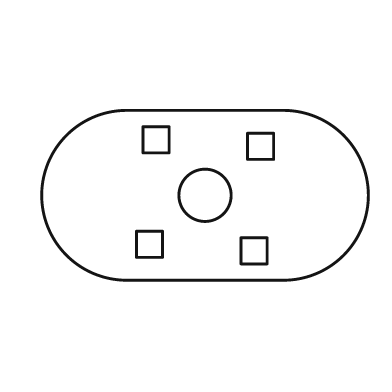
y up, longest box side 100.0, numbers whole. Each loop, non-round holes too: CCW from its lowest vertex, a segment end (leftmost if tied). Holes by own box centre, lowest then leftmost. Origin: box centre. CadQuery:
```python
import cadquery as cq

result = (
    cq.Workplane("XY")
    .moveTo(-24.0, -26.0)
    .lineTo(24.0, -26.0)
    .threePointArc((50.0, 0.0), (24.0, 26.0))
    .lineTo(-24.0, 26.0)
    .threePointArc((-50.0, 0.0), (-24.0, -26.0))
    .close()
    .moveTo(11.0, -21.0)
    .lineTo(19.0, -21.0)
    .lineTo(19.0, -13.0)
    .lineTo(11.0, -13.0)
    .close()
    .moveTo(-21.0, -19.0)
    .lineTo(-13.0, -19.0)
    .lineTo(-13.0, -11.0)
    .lineTo(-21.0, -11.0)
    .close()
    .moveTo(0.0, 0.0)
    .circle(8.0)
    .moveTo(13.0, 11.0)
    .lineTo(21.0, 11.0)
    .lineTo(21.0, 19.0)
    .lineTo(13.0, 19.0)
    .close()
    .moveTo(-19.0, 13.0)
    .lineTo(-11.0, 13.0)
    .lineTo(-11.0, 21.0)
    .lineTo(-19.0, 21.0)
    .close()
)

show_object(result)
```